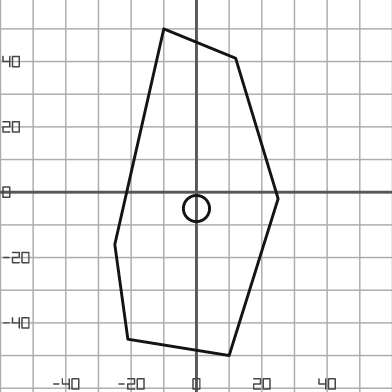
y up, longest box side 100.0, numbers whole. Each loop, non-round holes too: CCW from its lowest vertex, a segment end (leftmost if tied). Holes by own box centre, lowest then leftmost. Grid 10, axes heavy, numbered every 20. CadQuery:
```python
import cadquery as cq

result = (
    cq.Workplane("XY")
    .moveTo(10.0, -50.0)
    .lineTo(25.0, -2.0)
    .lineTo(12.0, 41.0)
    .lineTo(-10.0, 50.0)
    .lineTo(-25.0, -16.0)
    .lineTo(-21.0, -45.0)
    .close()
    .moveTo(0.0, -5.0)
    .circle(4.0)
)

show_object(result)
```